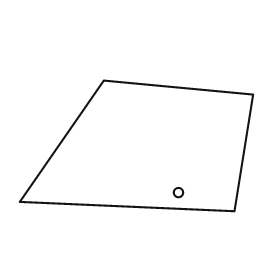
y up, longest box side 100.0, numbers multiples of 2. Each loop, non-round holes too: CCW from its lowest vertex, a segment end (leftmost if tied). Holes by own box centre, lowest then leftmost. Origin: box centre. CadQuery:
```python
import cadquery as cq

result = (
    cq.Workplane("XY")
    .moveTo(42.0, -28.0)
    .lineTo(50.0, 22.0)
    .lineTo(-14.0, 28.0)
    .lineTo(-50.0, -24.0)
    .close()
    .moveTo(18.0, -20.0)
    .circle(2.0)
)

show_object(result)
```